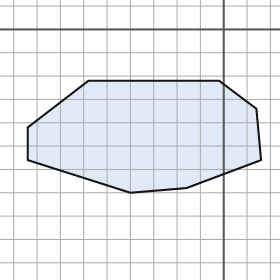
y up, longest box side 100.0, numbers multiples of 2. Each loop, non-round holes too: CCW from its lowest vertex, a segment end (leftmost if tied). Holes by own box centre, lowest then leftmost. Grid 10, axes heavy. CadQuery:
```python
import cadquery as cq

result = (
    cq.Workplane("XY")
    .moveTo(-40.0, -70.0)
    .lineTo(-16.0, -68.0)
    .lineTo(16.0, -56.0)
    .lineTo(14.0, -34.0)
    .lineTo(-2.0, -22.0)
    .lineTo(-58.0, -22.0)
    .lineTo(-84.0, -42.0)
    .lineTo(-84.0, -56.0)
    .close()
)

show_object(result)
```